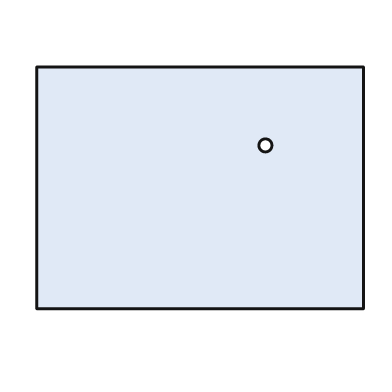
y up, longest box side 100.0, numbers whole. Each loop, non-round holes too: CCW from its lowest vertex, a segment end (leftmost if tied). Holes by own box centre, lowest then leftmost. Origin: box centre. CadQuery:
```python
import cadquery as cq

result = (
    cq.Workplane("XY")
    .moveTo(-50.0, -37.0)
    .lineTo(50.0, -37.0)
    .lineTo(50.0, 37.0)
    .lineTo(-50.0, 37.0)
    .close()
    .moveTo(20.0, 13.0)
    .circle(2.0)
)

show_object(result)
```